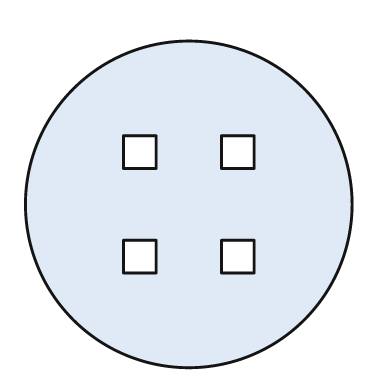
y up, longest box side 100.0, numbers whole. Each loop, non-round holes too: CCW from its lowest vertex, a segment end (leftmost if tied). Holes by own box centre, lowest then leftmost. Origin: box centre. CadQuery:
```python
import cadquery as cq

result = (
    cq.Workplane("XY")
    .moveTo(0.0, 0.0)
    .circle(50.0)
    .moveTo(-20.0, -21.0)
    .lineTo(-10.0, -21.0)
    .lineTo(-10.0, -11.0)
    .lineTo(-20.0, -11.0)
    .close()
    .moveTo(10.0, -21.0)
    .lineTo(20.0, -21.0)
    .lineTo(20.0, -11.0)
    .lineTo(10.0, -11.0)
    .close()
    .moveTo(-20.0, 11.0)
    .lineTo(-10.0, 11.0)
    .lineTo(-10.0, 21.0)
    .lineTo(-20.0, 21.0)
    .close()
    .moveTo(10.0, 11.0)
    .lineTo(20.0, 11.0)
    .lineTo(20.0, 21.0)
    .lineTo(10.0, 21.0)
    .close()
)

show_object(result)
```